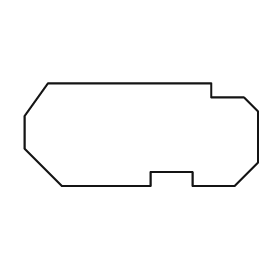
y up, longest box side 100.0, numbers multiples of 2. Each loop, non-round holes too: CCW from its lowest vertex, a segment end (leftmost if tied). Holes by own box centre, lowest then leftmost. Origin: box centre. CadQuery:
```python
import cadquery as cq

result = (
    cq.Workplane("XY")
    .moveTo(-34.0, -22.0)
    .lineTo(4.0, -22.0)
    .lineTo(4.0, -16.0)
    .lineTo(22.0, -16.0)
    .lineTo(22.0, -22.0)
    .lineTo(40.0, -22.0)
    .lineTo(50.0, -12.0)
    .lineTo(50.0, 10.0)
    .lineTo(44.0, 16.0)
    .lineTo(30.0, 16.0)
    .lineTo(30.0, 22.0)
    .lineTo(-40.0, 22.0)
    .lineTo(-50.0, 8.0)
    .lineTo(-50.0, -6.0)
    .close()
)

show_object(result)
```